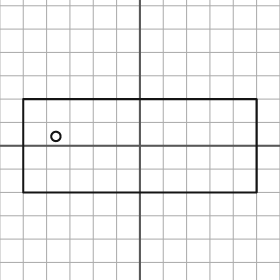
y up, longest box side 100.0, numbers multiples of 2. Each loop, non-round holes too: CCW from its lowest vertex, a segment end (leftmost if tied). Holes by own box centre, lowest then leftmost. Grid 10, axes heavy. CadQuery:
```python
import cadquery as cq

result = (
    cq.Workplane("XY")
    .moveTo(-50.0, -20.0)
    .lineTo(50.0, -20.0)
    .lineTo(50.0, 20.0)
    .lineTo(-50.0, 20.0)
    .close()
    .moveTo(-36.0, 4.0)
    .circle(2.0)
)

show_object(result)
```